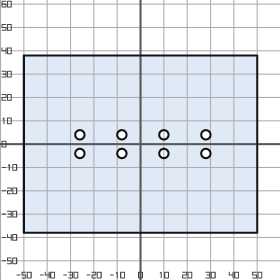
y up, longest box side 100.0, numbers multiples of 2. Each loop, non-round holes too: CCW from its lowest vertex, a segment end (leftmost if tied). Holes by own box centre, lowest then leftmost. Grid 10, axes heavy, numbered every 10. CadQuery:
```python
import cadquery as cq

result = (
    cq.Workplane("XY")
    .moveTo(-50.0, -38.0)
    .lineTo(50.0, -38.0)
    .lineTo(50.0, 38.0)
    .lineTo(-50.0, 38.0)
    .close()
    .moveTo(-26.0, -4.0)
    .circle(2.0)
    .moveTo(-8.0, -4.0)
    .circle(2.0)
    .moveTo(10.0, -4.0)
    .circle(2.0)
    .moveTo(28.0, -4.0)
    .circle(2.0)
    .moveTo(-26.0, 4.0)
    .circle(2.0)
    .moveTo(-8.0, 4.0)
    .circle(2.0)
    .moveTo(10.0, 4.0)
    .circle(2.0)
    .moveTo(28.0, 4.0)
    .circle(2.0)
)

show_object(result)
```